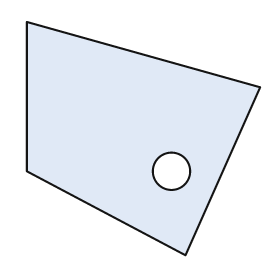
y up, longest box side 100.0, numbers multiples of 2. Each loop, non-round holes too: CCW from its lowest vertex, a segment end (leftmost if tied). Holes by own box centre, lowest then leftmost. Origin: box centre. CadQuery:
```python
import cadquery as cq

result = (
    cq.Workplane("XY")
    .moveTo(18.0, -50.0)
    .lineTo(50.0, 22.0)
    .lineTo(-50.0, 50.0)
    .lineTo(-50.0, -14.0)
    .close()
    .moveTo(12.0, -14.0)
    .circle(8.0)
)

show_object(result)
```